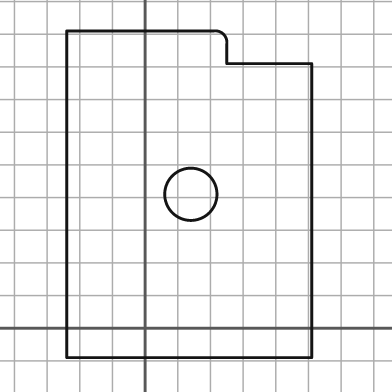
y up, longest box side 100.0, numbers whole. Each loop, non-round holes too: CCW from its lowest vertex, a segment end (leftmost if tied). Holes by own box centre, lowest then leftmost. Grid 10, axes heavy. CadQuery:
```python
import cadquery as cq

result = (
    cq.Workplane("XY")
    .moveTo(-24.0, -9.0)
    .lineTo(51.0, -9.0)
    .lineTo(51.0, 81.0)
    .lineTo(25.0, 81.0)
    .lineTo(25.0, 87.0)
    .threePointArc((24.0, 90.0), (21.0, 91.0))
    .lineTo(-24.0, 91.0)
    .close()
    .moveTo(14.0, 41.0)
    .circle(8.0)
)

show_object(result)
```